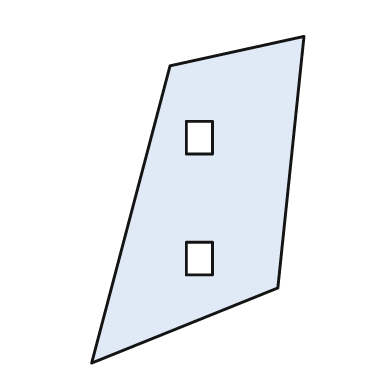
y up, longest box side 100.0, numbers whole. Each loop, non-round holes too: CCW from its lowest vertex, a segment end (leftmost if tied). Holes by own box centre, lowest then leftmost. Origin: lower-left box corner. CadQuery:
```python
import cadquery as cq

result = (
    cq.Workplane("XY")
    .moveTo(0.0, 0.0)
    .lineTo(57.0, 23.0)
    .lineTo(65.0, 100.0)
    .lineTo(24.0, 91.0)
    .close()
    .moveTo(29.0, 27.0)
    .lineTo(37.0, 27.0)
    .lineTo(37.0, 37.0)
    .lineTo(29.0, 37.0)
    .close()
    .moveTo(29.0, 64.0)
    .lineTo(37.0, 64.0)
    .lineTo(37.0, 74.0)
    .lineTo(29.0, 74.0)
    .close()
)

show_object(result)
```